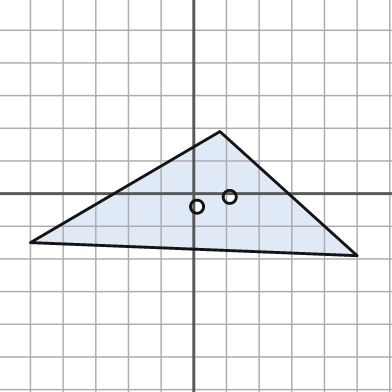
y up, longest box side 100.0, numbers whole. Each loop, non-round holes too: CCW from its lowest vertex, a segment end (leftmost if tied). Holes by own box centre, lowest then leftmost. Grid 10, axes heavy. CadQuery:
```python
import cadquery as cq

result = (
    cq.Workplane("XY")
    .moveTo(50.0, -19.0)
    .lineTo(8.0, 19.0)
    .lineTo(-50.0, -15.0)
    .close()
    .moveTo(1.0, -4.0)
    .circle(2.0)
    .moveTo(11.0, -1.0)
    .circle(2.0)
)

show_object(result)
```